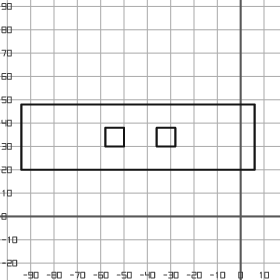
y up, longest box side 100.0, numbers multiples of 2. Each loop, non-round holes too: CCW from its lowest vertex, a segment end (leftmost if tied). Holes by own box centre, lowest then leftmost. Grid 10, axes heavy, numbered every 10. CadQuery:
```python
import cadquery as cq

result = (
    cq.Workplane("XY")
    .moveTo(-94.0, 20.0)
    .lineTo(6.0, 20.0)
    .lineTo(6.0, 48.0)
    .lineTo(-94.0, 48.0)
    .close()
    .moveTo(-58.0, 30.0)
    .lineTo(-50.0, 30.0)
    .lineTo(-50.0, 38.0)
    .lineTo(-58.0, 38.0)
    .close()
    .moveTo(-36.0, 30.0)
    .lineTo(-28.0, 30.0)
    .lineTo(-28.0, 38.0)
    .lineTo(-36.0, 38.0)
    .close()
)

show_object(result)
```